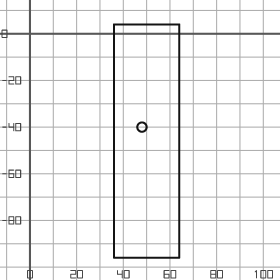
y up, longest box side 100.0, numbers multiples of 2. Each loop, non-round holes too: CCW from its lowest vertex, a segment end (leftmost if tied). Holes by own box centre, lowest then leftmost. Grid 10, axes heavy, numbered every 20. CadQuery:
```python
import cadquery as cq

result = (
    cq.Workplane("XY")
    .moveTo(36.0, -96.0)
    .lineTo(64.0, -96.0)
    .lineTo(64.0, 4.0)
    .lineTo(36.0, 4.0)
    .close()
    .moveTo(48.0, -40.0)
    .circle(2.0)
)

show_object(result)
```